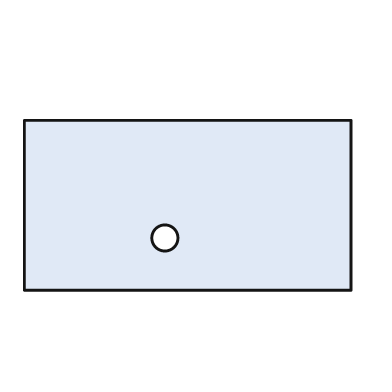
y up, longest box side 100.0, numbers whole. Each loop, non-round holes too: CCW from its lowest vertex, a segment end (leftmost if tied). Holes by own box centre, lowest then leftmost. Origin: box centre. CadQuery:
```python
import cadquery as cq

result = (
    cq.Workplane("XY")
    .moveTo(-50.0, -26.0)
    .lineTo(50.0, -26.0)
    .lineTo(50.0, 26.0)
    .lineTo(-50.0, 26.0)
    .close()
    .moveTo(-7.0, -10.0)
    .circle(4.0)
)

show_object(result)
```